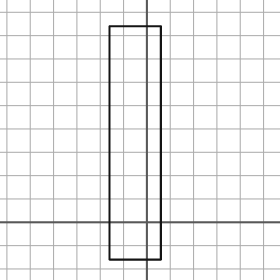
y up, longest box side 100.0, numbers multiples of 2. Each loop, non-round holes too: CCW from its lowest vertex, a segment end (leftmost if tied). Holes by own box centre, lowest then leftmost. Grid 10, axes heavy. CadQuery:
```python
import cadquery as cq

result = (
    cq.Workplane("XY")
    .moveTo(-16.0, -16.0)
    .lineTo(6.0, -16.0)
    .lineTo(6.0, 84.0)
    .lineTo(-16.0, 84.0)
    .close()
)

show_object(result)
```